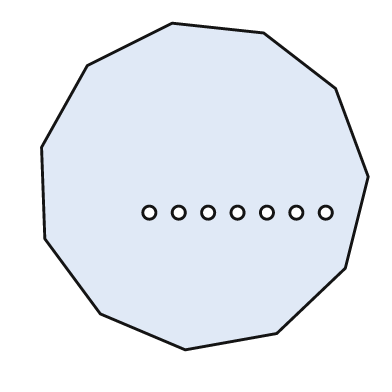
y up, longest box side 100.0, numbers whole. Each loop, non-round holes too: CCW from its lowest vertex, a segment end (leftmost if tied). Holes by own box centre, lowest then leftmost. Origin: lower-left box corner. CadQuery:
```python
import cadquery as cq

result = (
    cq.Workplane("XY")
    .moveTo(44.0, 0.0)
    .lineTo(72.0, 5.0)
    .lineTo(93.0, 25.0)
    .lineTo(100.0, 53.0)
    .lineTo(90.0, 80.0)
    .lineTo(68.0, 97.0)
    .lineTo(40.0, 100.0)
    .lineTo(14.0, 87.0)
    .lineTo(0.0, 62.0)
    .lineTo(1.0, 34.0)
    .lineTo(18.0, 11.0)
    .close()
    .moveTo(33.0, 42.0)
    .circle(2.0)
    .moveTo(42.0, 42.0)
    .circle(2.0)
    .moveTo(51.0, 42.0)
    .circle(2.0)
    .moveTo(60.0, 42.0)
    .circle(2.0)
    .moveTo(69.0, 42.0)
    .circle(2.0)
    .moveTo(78.0, 42.0)
    .circle(2.0)
    .moveTo(87.0, 42.0)
    .circle(2.0)
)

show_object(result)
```